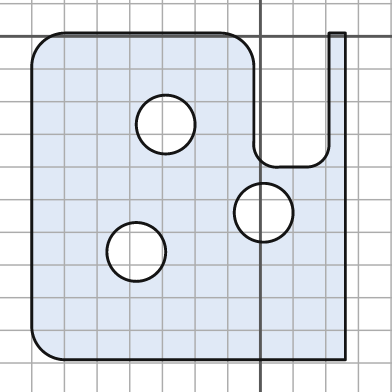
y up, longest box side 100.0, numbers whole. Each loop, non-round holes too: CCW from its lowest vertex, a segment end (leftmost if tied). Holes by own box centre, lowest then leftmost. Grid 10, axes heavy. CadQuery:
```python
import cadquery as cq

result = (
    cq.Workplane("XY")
    .moveTo(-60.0, -99.0)
    .lineTo(26.0, -99.0)
    .lineTo(26.0, 1.0)
    .lineTo(21.0, 1.0)
    .lineTo(21.0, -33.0)
    .threePointArc((19.0, -38.0), (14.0, -40.0))
    .lineTo(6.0, -40.0)
    .threePointArc((0.0, -38.0), (-2.0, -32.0))
    .lineTo(-2.0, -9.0)
    .threePointArc((-5.0, -2.0), (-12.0, 1.0))
    .lineTo(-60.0, 1.0)
    .threePointArc((-67.0, -2.0), (-70.0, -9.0))
    .lineTo(-70.0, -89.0)
    .threePointArc((-67.0, -96.0), (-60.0, -99.0))
    .close()
    .moveTo(-38.0, -66.0)
    .circle(9.0)
    .moveTo(1.0, -54.0)
    .circle(9.0)
    .moveTo(-29.0, -27.0)
    .circle(9.0)
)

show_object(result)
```